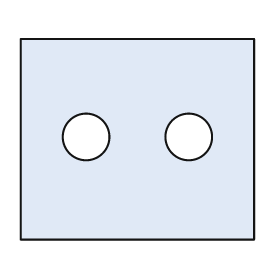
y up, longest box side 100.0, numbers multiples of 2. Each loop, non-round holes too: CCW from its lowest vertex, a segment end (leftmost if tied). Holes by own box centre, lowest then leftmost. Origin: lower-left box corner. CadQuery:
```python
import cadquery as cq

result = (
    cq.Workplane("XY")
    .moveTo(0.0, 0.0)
    .lineTo(100.0, 0.0)
    .lineTo(100.0, 86.0)
    .lineTo(0.0, 86.0)
    .close()
    .moveTo(28.0, 44.0)
    .circle(10.0)
    .moveTo(72.0, 44.0)
    .circle(10.0)
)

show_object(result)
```